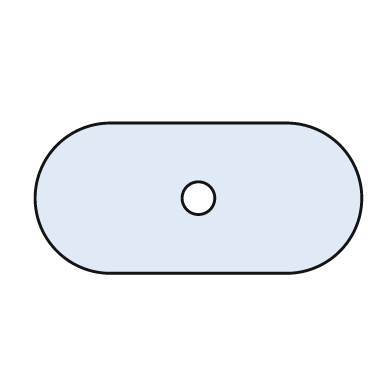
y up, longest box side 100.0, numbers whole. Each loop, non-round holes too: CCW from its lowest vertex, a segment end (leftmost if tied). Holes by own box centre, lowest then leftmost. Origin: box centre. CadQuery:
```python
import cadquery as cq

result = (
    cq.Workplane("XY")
    .moveTo(-27.0, -23.0)
    .lineTo(27.0, -23.0)
    .threePointArc((50.0, 0.0), (27.0, 23.0))
    .lineTo(-27.0, 23.0)
    .threePointArc((-50.0, 0.0), (-27.0, -23.0))
    .close()
    .moveTo(0.0, 0.0)
    .circle(5.0)
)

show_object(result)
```